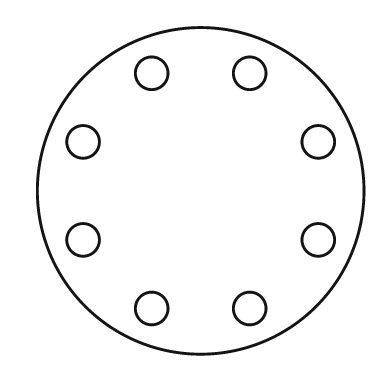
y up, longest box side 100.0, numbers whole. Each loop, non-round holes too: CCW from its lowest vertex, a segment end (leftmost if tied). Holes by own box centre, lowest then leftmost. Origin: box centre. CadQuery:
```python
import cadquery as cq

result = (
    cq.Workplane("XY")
    .moveTo(0.0, 0.0)
    .circle(50.0)
    .moveTo(-15.0, -36.0)
    .circle(5.0)
    .moveTo(15.0, -36.0)
    .circle(5.0)
    .moveTo(-36.0, -15.0)
    .circle(5.0)
    .moveTo(36.0, -15.0)
    .circle(5.0)
    .moveTo(-36.0, 15.0)
    .circle(5.0)
    .moveTo(36.0, 15.0)
    .circle(5.0)
    .moveTo(-15.0, 36.0)
    .circle(5.0)
    .moveTo(15.0, 36.0)
    .circle(5.0)
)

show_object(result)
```